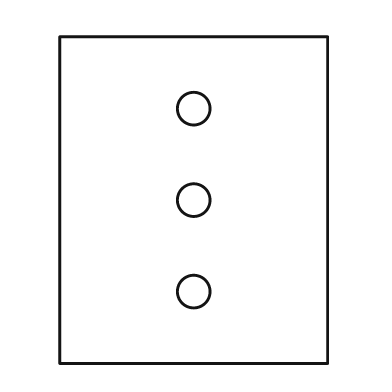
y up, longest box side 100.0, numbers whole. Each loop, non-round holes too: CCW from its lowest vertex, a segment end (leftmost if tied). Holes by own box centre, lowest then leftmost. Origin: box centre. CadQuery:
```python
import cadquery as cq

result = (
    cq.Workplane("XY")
    .moveTo(-41.0, -50.0)
    .lineTo(41.0, -50.0)
    .lineTo(41.0, 50.0)
    .lineTo(-41.0, 50.0)
    .close()
    .moveTo(0.0, -28.0)
    .circle(5.0)
    .moveTo(0.0, 0.0)
    .circle(5.0)
    .moveTo(0.0, 28.0)
    .circle(5.0)
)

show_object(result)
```